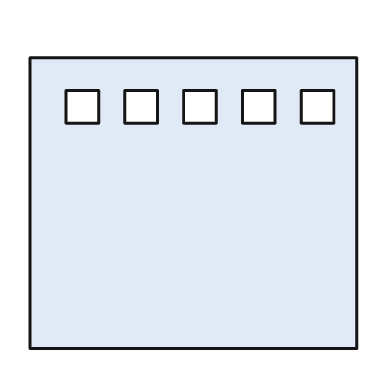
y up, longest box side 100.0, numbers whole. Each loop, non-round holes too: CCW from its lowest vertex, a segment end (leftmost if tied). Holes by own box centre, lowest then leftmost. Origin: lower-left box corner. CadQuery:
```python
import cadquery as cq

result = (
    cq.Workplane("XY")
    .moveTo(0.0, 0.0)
    .lineTo(100.0, 0.0)
    .lineTo(100.0, 89.0)
    .lineTo(0.0, 89.0)
    .close()
    .moveTo(11.0, 69.0)
    .lineTo(21.0, 69.0)
    .lineTo(21.0, 79.0)
    .lineTo(11.0, 79.0)
    .close()
    .moveTo(29.0, 69.0)
    .lineTo(39.0, 69.0)
    .lineTo(39.0, 79.0)
    .lineTo(29.0, 79.0)
    .close()
    .moveTo(47.0, 69.0)
    .lineTo(57.0, 69.0)
    .lineTo(57.0, 79.0)
    .lineTo(47.0, 79.0)
    .close()
    .moveTo(65.0, 69.0)
    .lineTo(75.0, 69.0)
    .lineTo(75.0, 79.0)
    .lineTo(65.0, 79.0)
    .close()
    .moveTo(83.0, 69.0)
    .lineTo(93.0, 69.0)
    .lineTo(93.0, 79.0)
    .lineTo(83.0, 79.0)
    .close()
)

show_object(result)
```